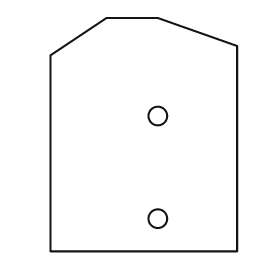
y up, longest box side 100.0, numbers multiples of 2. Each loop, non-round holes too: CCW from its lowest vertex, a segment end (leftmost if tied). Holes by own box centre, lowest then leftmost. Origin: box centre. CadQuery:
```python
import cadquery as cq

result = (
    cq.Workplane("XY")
    .moveTo(-40.0, -50.0)
    .lineTo(40.0, -50.0)
    .lineTo(40.0, 38.0)
    .lineTo(6.0, 50.0)
    .lineTo(-16.0, 50.0)
    .lineTo(-40.0, 34.0)
    .close()
    .moveTo(6.0, -36.0)
    .circle(4.0)
    .moveTo(6.0, 8.0)
    .circle(4.0)
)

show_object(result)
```